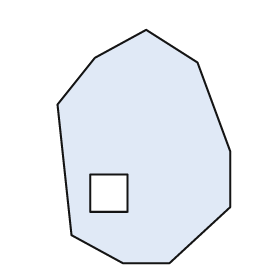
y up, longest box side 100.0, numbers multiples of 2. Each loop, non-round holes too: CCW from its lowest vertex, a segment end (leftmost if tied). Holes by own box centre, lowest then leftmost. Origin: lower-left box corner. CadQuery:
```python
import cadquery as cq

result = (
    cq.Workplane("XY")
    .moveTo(28.0, 0.0)
    .lineTo(48.0, 0.0)
    .lineTo(74.0, 24.0)
    .lineTo(74.0, 48.0)
    .lineTo(60.0, 86.0)
    .lineTo(38.0, 100.0)
    .lineTo(16.0, 88.0)
    .lineTo(0.0, 68.0)
    .lineTo(6.0, 12.0)
    .close()
    .moveTo(14.0, 22.0)
    .lineTo(30.0, 22.0)
    .lineTo(30.0, 38.0)
    .lineTo(14.0, 38.0)
    .close()
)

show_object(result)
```